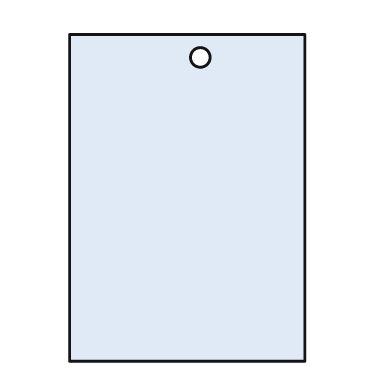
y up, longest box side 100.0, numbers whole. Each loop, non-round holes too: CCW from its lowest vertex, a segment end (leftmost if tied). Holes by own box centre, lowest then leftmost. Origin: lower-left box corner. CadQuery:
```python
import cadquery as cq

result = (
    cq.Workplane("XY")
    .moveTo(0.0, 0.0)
    .lineTo(72.0, 0.0)
    .lineTo(72.0, 100.0)
    .lineTo(0.0, 100.0)
    .close()
    .moveTo(40.0, 93.0)
    .circle(3.0)
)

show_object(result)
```